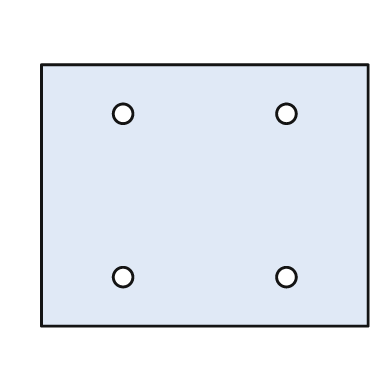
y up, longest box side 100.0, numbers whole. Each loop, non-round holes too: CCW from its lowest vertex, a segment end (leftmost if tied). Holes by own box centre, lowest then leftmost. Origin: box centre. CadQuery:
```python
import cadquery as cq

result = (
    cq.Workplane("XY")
    .moveTo(-50.0, -40.0)
    .lineTo(50.0, -40.0)
    .lineTo(50.0, 40.0)
    .lineTo(-50.0, 40.0)
    .close()
    .moveTo(-25.0, -25.0)
    .circle(3.0)
    .moveTo(25.0, -25.0)
    .circle(3.0)
    .moveTo(-25.0, 25.0)
    .circle(3.0)
    .moveTo(25.0, 25.0)
    .circle(3.0)
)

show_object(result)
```